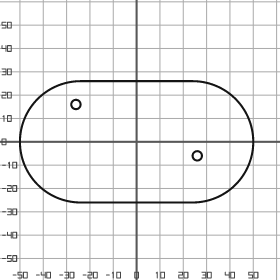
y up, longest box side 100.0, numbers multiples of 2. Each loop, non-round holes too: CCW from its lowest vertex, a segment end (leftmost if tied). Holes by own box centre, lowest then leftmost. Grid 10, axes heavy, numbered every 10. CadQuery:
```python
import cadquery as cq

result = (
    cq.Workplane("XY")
    .moveTo(-24.0, -26.0)
    .lineTo(24.0, -26.0)
    .threePointArc((50.0, 0.0), (24.0, 26.0))
    .lineTo(-24.0, 26.0)
    .threePointArc((-50.0, 0.0), (-24.0, -26.0))
    .close()
    .moveTo(26.0, -6.0)
    .circle(2.0)
    .moveTo(-26.0, 16.0)
    .circle(2.0)
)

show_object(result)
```